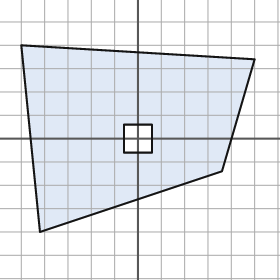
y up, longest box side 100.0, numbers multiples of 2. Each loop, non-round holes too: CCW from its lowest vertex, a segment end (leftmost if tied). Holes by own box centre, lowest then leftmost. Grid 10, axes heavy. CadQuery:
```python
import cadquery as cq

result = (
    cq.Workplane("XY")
    .moveTo(-42.0, -40.0)
    .lineTo(36.0, -14.0)
    .lineTo(50.0, 34.0)
    .lineTo(-50.0, 40.0)
    .close()
    .moveTo(-6.0, -6.0)
    .lineTo(6.0, -6.0)
    .lineTo(6.0, 6.0)
    .lineTo(-6.0, 6.0)
    .close()
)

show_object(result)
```